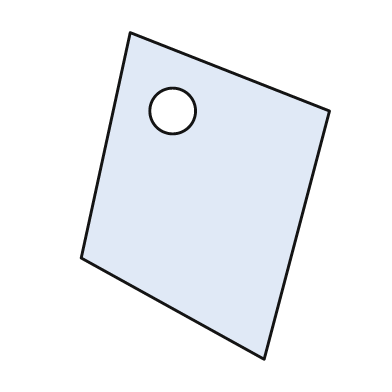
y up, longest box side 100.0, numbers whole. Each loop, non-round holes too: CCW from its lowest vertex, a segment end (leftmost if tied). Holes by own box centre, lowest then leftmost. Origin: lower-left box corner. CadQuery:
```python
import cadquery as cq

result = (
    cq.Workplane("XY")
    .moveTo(56.0, 0.0)
    .lineTo(76.0, 76.0)
    .lineTo(15.0, 100.0)
    .lineTo(0.0, 31.0)
    .close()
    .moveTo(28.0, 76.0)
    .circle(7.0)
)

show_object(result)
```